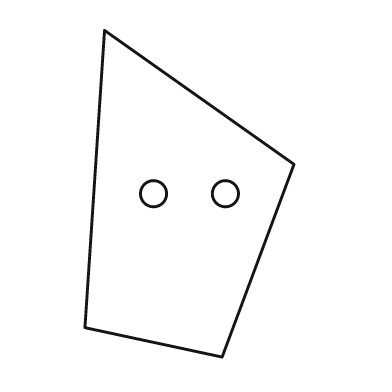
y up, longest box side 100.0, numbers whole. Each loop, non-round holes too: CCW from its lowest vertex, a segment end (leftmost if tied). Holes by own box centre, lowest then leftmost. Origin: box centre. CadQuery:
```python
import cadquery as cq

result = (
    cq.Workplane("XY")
    .moveTo(10.0, -50.0)
    .lineTo(32.0, 9.0)
    .lineTo(-26.0, 50.0)
    .lineTo(-32.0, -41.0)
    .close()
    .moveTo(-11.0, 0.0)
    .circle(4.0)
    .moveTo(11.0, 0.0)
    .circle(4.0)
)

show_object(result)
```